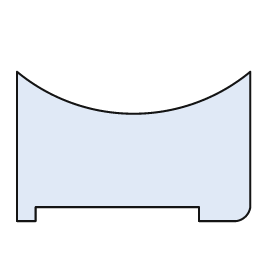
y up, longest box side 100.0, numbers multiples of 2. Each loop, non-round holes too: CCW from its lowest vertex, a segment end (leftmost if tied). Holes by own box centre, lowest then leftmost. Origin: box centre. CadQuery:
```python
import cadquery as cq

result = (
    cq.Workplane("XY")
    .moveTo(-50.0, -32.0)
    .lineTo(-42.0, -32.0)
    .lineTo(-42.0, -26.0)
    .lineTo(28.0, -26.0)
    .lineTo(28.0, -32.0)
    .lineTo(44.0, -32.0)
    .threePointArc((48.0, -30.0), (50.0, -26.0))
    .lineTo(50.0, 32.0)
    .threePointArc((0.0, 14.0), (-50.0, 32.0))
    .close()
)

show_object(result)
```